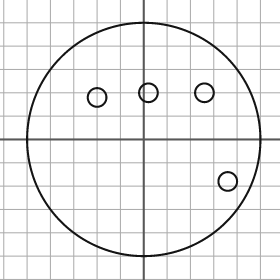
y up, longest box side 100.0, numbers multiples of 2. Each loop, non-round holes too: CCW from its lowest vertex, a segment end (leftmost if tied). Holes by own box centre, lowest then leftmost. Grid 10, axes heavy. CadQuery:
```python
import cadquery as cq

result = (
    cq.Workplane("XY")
    .moveTo(0.0, 0.0)
    .circle(50.0)
    .moveTo(36.0, -18.0)
    .circle(4.0)
    .moveTo(-20.0, 18.0)
    .circle(4.0)
    .moveTo(2.0, 20.0)
    .circle(4.0)
    .moveTo(26.0, 20.0)
    .circle(4.0)
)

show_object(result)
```